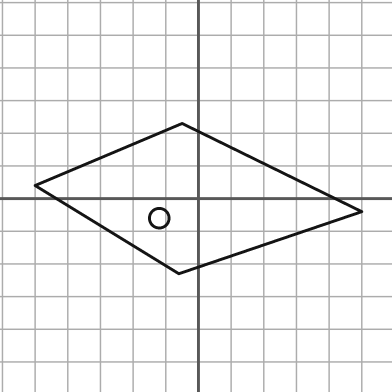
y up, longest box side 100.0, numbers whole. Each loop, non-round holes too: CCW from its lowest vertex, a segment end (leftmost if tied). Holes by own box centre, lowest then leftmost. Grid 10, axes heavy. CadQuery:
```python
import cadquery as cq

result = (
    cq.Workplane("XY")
    .moveTo(-6.0, -23.0)
    .lineTo(50.0, -4.0)
    .lineTo(-5.0, 23.0)
    .lineTo(-50.0, 4.0)
    .close()
    .moveTo(-12.0, -6.0)
    .circle(3.0)
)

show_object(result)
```